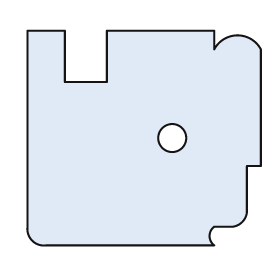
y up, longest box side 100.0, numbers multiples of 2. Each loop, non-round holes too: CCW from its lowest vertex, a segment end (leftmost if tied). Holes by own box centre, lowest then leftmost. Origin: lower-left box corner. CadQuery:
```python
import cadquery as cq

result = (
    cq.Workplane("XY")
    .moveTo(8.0, 0.0)
    .lineTo(80.0, 0.0)
    .threePointArc((78.0, 4.0), (80.0, 8.0))
    .lineTo(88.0, 8.0)
    .threePointArc((92.0, 10.0), (94.0, 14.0))
    .lineTo(94.0, 34.0)
    .lineTo(100.0, 34.0)
    .lineTo(100.0, 84.0)
    .threePointArc((90.0, 90.0), (80.0, 84.0))
    .lineTo(80.0, 92.0)
    .lineTo(34.0, 92.0)
    .lineTo(34.0, 70.0)
    .lineTo(16.0, 70.0)
    .lineTo(16.0, 92.0)
    .lineTo(0.0, 92.0)
    .lineTo(0.0, 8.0)
    .threePointArc((2.0, 2.0), (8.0, 0.0))
    .close()
    .moveTo(62.0, 46.0)
    .circle(6.0)
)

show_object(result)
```